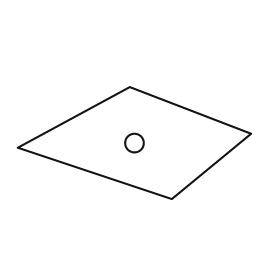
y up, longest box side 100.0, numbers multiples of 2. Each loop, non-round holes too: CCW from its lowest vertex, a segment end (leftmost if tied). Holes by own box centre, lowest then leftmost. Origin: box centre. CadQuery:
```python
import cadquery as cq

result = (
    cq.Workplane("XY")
    .moveTo(16.0, -24.0)
    .lineTo(50.0, 4.0)
    .lineTo(-2.0, 24.0)
    .lineTo(-50.0, -2.0)
    .close()
    .moveTo(0.0, 0.0)
    .circle(4.0)
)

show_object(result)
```